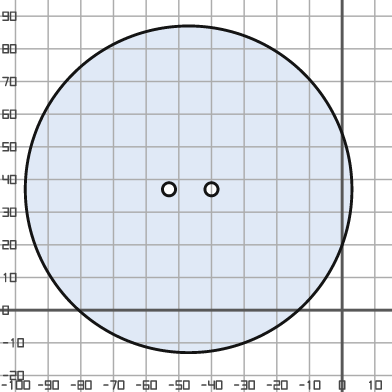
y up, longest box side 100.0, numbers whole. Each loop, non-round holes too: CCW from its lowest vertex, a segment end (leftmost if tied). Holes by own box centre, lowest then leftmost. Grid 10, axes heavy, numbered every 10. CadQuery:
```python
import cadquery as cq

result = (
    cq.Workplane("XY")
    .moveTo(-47.0, 37.0)
    .circle(50.0)
    .moveTo(-53.0, 37.0)
    .circle(2.0)
    .moveTo(-40.0, 37.0)
    .circle(2.0)
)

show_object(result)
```